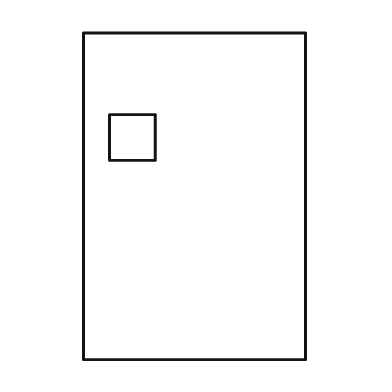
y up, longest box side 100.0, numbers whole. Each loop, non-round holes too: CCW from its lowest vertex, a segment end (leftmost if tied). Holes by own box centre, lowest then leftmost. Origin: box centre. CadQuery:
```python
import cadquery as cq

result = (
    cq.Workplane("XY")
    .moveTo(-34.0, -50.0)
    .lineTo(34.0, -50.0)
    .lineTo(34.0, 50.0)
    .lineTo(-34.0, 50.0)
    .close()
    .moveTo(-26.0, 11.0)
    .lineTo(-12.0, 11.0)
    .lineTo(-12.0, 25.0)
    .lineTo(-26.0, 25.0)
    .close()
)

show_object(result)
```